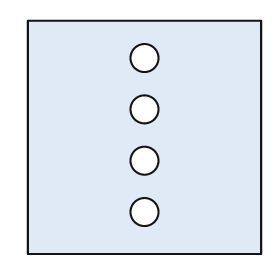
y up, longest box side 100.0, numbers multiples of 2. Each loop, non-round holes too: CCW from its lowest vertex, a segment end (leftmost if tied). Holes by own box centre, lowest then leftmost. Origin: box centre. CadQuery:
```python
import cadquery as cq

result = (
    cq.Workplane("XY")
    .moveTo(-50.0, -50.0)
    .lineTo(50.0, -50.0)
    .lineTo(50.0, 50.0)
    .lineTo(-50.0, 50.0)
    .close()
    .moveTo(0.0, -32.0)
    .circle(6.0)
    .moveTo(0.0, -10.0)
    .circle(6.0)
    .moveTo(0.0, 12.0)
    .circle(6.0)
    .moveTo(0.0, 34.0)
    .circle(6.0)
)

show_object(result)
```